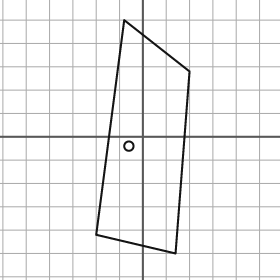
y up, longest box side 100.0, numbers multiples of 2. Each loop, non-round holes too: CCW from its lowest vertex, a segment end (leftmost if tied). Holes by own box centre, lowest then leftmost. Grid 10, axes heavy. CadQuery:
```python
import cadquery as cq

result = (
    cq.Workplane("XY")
    .moveTo(14.0, -50.0)
    .lineTo(20.0, 28.0)
    .lineTo(-8.0, 50.0)
    .lineTo(-20.0, -42.0)
    .close()
    .moveTo(-6.0, -4.0)
    .circle(2.0)
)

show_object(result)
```